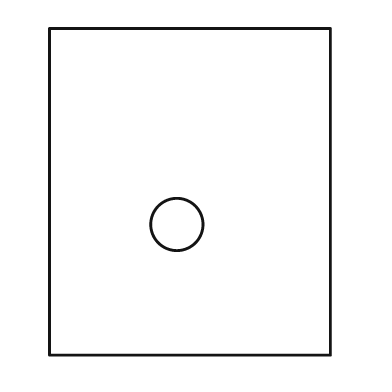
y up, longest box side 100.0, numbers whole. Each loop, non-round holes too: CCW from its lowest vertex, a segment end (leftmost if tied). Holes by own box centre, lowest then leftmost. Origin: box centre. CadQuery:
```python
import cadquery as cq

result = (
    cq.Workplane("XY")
    .moveTo(-43.0, -50.0)
    .lineTo(43.0, -50.0)
    .lineTo(43.0, 50.0)
    .lineTo(-43.0, 50.0)
    .close()
    .moveTo(-4.0, -10.0)
    .circle(8.0)
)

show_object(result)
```